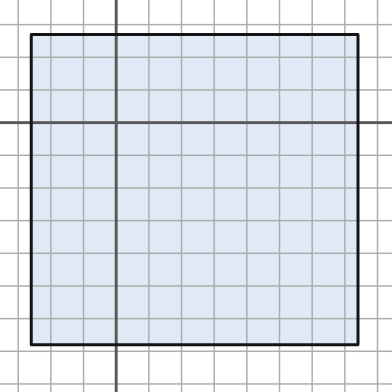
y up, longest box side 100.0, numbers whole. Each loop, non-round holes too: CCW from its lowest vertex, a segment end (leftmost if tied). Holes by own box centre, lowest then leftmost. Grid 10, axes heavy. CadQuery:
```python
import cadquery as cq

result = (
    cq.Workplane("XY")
    .moveTo(-26.0, -68.0)
    .lineTo(74.0, -68.0)
    .lineTo(74.0, 27.0)
    .lineTo(-26.0, 27.0)
    .close()
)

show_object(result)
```